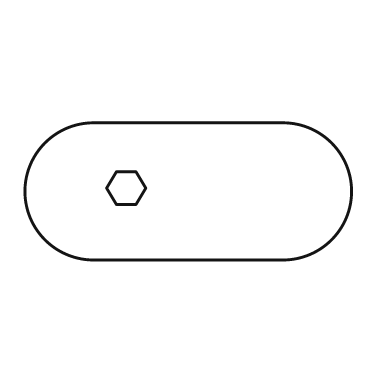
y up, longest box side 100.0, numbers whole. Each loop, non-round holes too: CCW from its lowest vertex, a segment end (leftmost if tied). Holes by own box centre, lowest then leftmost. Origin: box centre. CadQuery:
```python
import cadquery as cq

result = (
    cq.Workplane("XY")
    .moveTo(-29.0, -21.0)
    .lineTo(29.0, -21.0)
    .threePointArc((50.0, 0.0), (29.0, 21.0))
    .lineTo(-29.0, 21.0)
    .threePointArc((-50.0, 0.0), (-29.0, -21.0))
    .close()
    .moveTo(-22.0, -4.0)
    .lineTo(-16.0, -4.0)
    .lineTo(-13.0, 1.0)
    .lineTo(-16.0, 6.0)
    .lineTo(-22.0, 6.0)
    .lineTo(-25.0, 1.0)
    .close()
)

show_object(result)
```